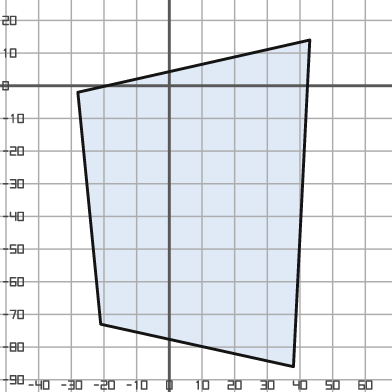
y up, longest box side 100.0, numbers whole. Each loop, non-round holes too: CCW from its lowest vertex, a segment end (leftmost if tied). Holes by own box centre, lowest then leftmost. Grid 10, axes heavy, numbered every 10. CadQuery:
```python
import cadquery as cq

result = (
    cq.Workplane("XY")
    .moveTo(38.0, -86.0)
    .lineTo(43.0, 14.0)
    .lineTo(-28.0, -2.0)
    .lineTo(-21.0, -73.0)
    .close()
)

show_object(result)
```